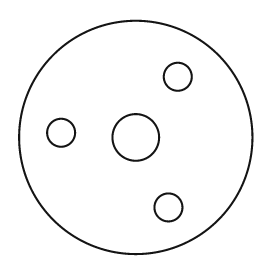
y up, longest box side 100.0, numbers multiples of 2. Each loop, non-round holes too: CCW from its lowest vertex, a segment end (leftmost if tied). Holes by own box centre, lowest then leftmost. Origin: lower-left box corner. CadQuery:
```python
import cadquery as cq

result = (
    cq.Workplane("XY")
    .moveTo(50.0, 50.0)
    .circle(50.0)
    .moveTo(64.0, 20.0)
    .circle(6.0)
    .moveTo(50.0, 50.0)
    .circle(10.0)
    .moveTo(18.0, 52.0)
    .circle(6.0)
    .moveTo(68.0, 76.0)
    .circle(6.0)
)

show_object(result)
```